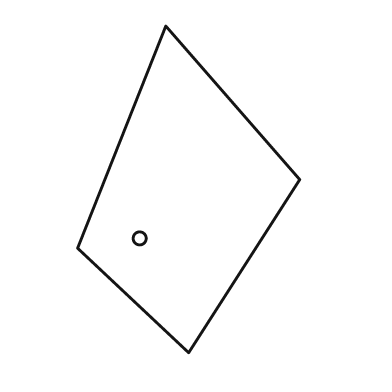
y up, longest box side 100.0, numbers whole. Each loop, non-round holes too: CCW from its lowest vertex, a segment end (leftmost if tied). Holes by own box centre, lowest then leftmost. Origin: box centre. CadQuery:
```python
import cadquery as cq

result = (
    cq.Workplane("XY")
    .moveTo(0.0, -50.0)
    .lineTo(34.0, 3.0)
    .lineTo(-7.0, 50.0)
    .lineTo(-34.0, -18.0)
    .close()
    .moveTo(-15.0, -15.0)
    .circle(2.0)
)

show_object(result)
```